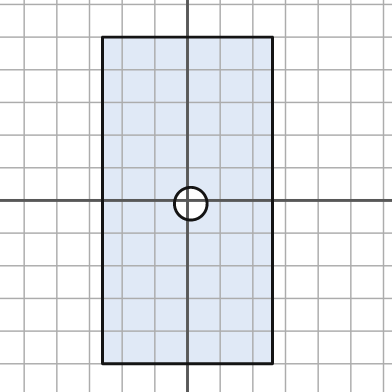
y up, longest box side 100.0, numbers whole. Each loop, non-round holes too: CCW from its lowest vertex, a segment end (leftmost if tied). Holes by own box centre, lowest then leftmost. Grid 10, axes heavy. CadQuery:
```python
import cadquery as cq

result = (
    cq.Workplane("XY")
    .moveTo(-26.0, -50.0)
    .lineTo(26.0, -50.0)
    .lineTo(26.0, 50.0)
    .lineTo(-26.0, 50.0)
    .close()
    .moveTo(1.0, -1.0)
    .circle(5.0)
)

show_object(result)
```